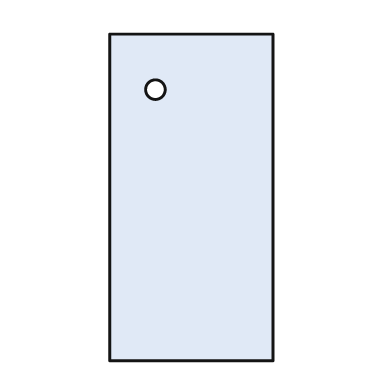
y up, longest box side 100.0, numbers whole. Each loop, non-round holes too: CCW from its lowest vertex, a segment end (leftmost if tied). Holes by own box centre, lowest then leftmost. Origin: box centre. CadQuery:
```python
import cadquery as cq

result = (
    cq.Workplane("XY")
    .moveTo(-25.0, -50.0)
    .lineTo(25.0, -50.0)
    .lineTo(25.0, 50.0)
    .lineTo(-25.0, 50.0)
    .close()
    .moveTo(-11.0, 33.0)
    .circle(3.0)
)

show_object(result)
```